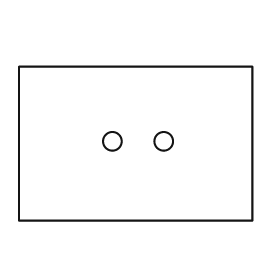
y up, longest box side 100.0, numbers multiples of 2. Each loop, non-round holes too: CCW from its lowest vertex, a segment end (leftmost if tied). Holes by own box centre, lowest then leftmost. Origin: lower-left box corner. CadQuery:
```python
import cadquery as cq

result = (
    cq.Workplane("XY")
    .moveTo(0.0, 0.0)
    .lineTo(100.0, 0.0)
    .lineTo(100.0, 66.0)
    .lineTo(0.0, 66.0)
    .close()
    .moveTo(40.0, 34.0)
    .circle(4.0)
    .moveTo(62.0, 34.0)
    .circle(4.0)
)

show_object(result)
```